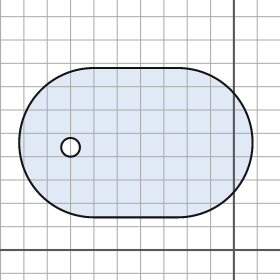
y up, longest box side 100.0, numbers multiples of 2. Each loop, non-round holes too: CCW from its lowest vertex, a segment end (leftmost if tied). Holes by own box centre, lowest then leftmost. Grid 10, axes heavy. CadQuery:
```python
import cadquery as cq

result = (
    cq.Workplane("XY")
    .moveTo(-60.0, 14.0)
    .lineTo(-24.0, 14.0)
    .threePointArc((8.0, 46.0), (-24.0, 78.0))
    .lineTo(-60.0, 78.0)
    .threePointArc((-92.0, 46.0), (-60.0, 14.0))
    .close()
    .moveTo(-70.0, 44.0)
    .circle(4.0)
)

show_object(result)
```